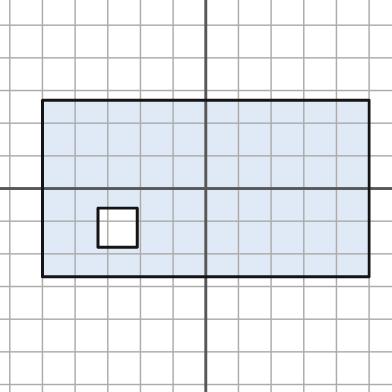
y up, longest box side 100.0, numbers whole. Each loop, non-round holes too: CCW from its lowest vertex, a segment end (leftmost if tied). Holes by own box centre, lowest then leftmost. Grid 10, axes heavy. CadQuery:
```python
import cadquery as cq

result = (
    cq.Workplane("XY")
    .moveTo(-50.0, -27.0)
    .lineTo(50.0, -27.0)
    .lineTo(50.0, 27.0)
    .lineTo(-50.0, 27.0)
    .close()
    .moveTo(-33.0, -18.0)
    .lineTo(-21.0, -18.0)
    .lineTo(-21.0, -6.0)
    .lineTo(-33.0, -6.0)
    .close()
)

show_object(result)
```